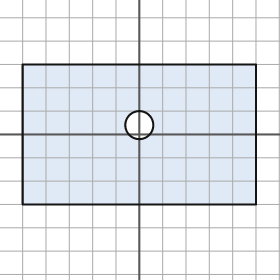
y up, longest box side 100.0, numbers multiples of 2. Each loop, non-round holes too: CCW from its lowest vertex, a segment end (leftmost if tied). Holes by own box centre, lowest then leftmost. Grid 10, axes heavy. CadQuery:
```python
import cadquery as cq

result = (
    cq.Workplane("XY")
    .moveTo(-50.0, -30.0)
    .lineTo(50.0, -30.0)
    .lineTo(50.0, 30.0)
    .lineTo(-50.0, 30.0)
    .close()
    .moveTo(0.0, 4.0)
    .circle(6.0)
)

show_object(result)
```